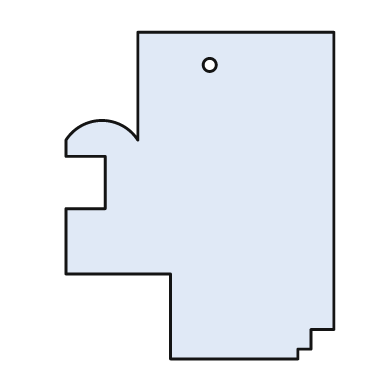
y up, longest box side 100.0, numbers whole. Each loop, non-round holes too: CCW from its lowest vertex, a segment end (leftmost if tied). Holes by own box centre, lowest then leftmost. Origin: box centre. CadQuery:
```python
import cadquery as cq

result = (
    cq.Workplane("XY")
    .moveTo(-9.0, -50.0)
    .lineTo(30.0, -50.0)
    .lineTo(30.0, -47.0)
    .lineTo(34.0, -47.0)
    .lineTo(34.0, -41.0)
    .lineTo(41.0, -41.0)
    .lineTo(41.0, 50.0)
    .lineTo(-19.0, 50.0)
    .lineTo(-19.0, 17.0)
    .threePointArc((-30.0, 23.0), (-41.0, 17.0))
    .lineTo(-41.0, 12.0)
    .lineTo(-29.0, 12.0)
    .lineTo(-29.0, -4.0)
    .lineTo(-41.0, -4.0)
    .lineTo(-41.0, -24.0)
    .lineTo(-9.0, -24.0)
    .close()
    .moveTo(3.0, 40.0)
    .circle(2.0)
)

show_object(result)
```